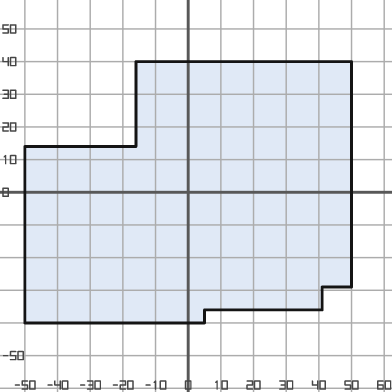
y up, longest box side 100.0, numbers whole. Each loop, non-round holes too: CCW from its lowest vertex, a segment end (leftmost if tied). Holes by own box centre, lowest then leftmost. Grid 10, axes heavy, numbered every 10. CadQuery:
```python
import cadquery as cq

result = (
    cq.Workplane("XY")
    .moveTo(-50.0, -40.0)
    .lineTo(5.0, -40.0)
    .lineTo(5.0, -36.0)
    .lineTo(41.0, -36.0)
    .lineTo(41.0, -29.0)
    .lineTo(50.0, -29.0)
    .lineTo(50.0, 40.0)
    .lineTo(-16.0, 40.0)
    .lineTo(-16.0, 14.0)
    .lineTo(-50.0, 14.0)
    .close()
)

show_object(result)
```